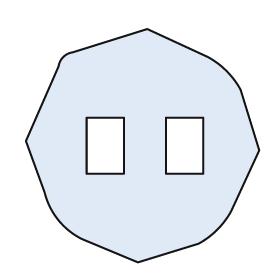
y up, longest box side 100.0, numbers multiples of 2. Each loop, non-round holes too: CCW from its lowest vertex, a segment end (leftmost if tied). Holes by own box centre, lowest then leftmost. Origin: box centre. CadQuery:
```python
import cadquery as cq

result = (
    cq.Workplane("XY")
    .moveTo(-2.0, -50.0)
    .lineTo(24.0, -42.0)
    .threePointArc((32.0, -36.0), (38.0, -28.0))
    .lineTo(50.0, -2.0)
    .lineTo(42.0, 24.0)
    .threePointArc((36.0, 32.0), (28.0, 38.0))
    .lineTo(2.0, 50.0)
    .lineTo(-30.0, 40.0)
    .threePointArc((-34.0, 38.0), (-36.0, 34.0))
    .lineTo(-50.0, 2.0)
    .lineTo(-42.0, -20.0)
    .threePointArc((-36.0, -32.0), (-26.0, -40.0))
    .close()
    .moveTo(-24.0, -12.0)
    .lineTo(-8.0, -12.0)
    .lineTo(-8.0, 12.0)
    .lineTo(-24.0, 12.0)
    .close()
    .moveTo(10.0, -12.0)
    .lineTo(26.0, -12.0)
    .lineTo(26.0, 12.0)
    .lineTo(10.0, 12.0)
    .close()
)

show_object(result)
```